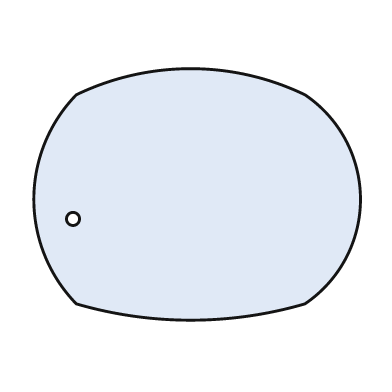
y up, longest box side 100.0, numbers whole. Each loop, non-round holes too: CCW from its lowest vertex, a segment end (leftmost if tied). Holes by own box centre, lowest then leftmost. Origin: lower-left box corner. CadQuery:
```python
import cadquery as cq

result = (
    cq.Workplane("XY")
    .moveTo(13.0, 5.0)
    .threePointArc((48.0, 0.0), (83.0, 5.0))
    .threePointArc((100.0, 37.0), (83.0, 69.0))
    .threePointArc((48.0, 77.0), (13.0, 69.0))
    .threePointArc((0.0, 37.0), (13.0, 5.0))
    .close()
    .moveTo(12.0, 31.0)
    .circle(2.0)
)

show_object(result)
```